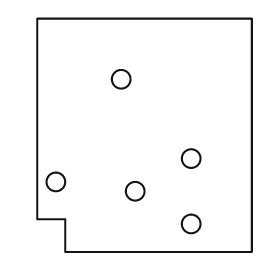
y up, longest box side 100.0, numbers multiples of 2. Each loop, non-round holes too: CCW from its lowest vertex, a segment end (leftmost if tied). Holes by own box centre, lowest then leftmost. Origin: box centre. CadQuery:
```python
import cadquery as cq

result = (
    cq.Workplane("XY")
    .moveTo(-34.0, -50.0)
    .lineTo(46.0, -50.0)
    .lineTo(46.0, 50.0)
    .lineTo(-46.0, 50.0)
    .lineTo(-46.0, -36.0)
    .lineTo(-34.0, -36.0)
    .close()
    .moveTo(20.0, -38.0)
    .circle(4.0)
    .moveTo(-4.0, -24.0)
    .circle(4.0)
    .moveTo(-38.0, -20.0)
    .circle(4.0)
    .moveTo(20.0, -10.0)
    .circle(4.0)
    .moveTo(-10.0, 24.0)
    .circle(4.0)
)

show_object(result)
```